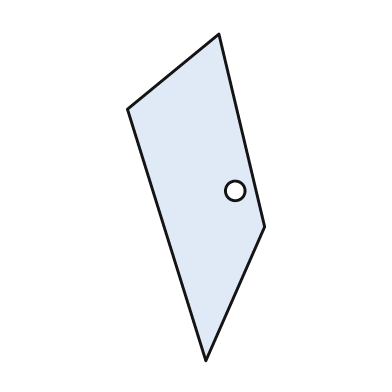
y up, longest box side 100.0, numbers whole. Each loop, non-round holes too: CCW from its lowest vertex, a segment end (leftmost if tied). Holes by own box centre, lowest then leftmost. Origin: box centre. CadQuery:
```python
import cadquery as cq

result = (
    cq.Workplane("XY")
    .moveTo(3.0, -50.0)
    .lineTo(21.0, -9.0)
    .lineTo(7.0, 50.0)
    .lineTo(-21.0, 27.0)
    .close()
    .moveTo(12.0, 2.0)
    .circle(3.0)
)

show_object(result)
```